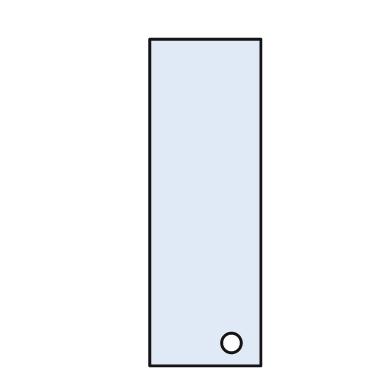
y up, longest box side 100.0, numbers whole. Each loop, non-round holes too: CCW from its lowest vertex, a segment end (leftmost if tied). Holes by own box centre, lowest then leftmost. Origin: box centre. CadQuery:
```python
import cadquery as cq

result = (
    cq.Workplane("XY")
    .moveTo(-17.0, -50.0)
    .lineTo(17.0, -50.0)
    .lineTo(17.0, 50.0)
    .lineTo(-17.0, 50.0)
    .close()
    .moveTo(8.0, -43.0)
    .circle(3.0)
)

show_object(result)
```